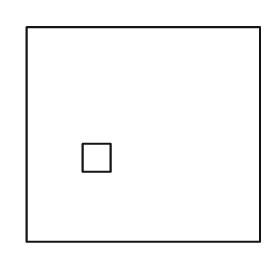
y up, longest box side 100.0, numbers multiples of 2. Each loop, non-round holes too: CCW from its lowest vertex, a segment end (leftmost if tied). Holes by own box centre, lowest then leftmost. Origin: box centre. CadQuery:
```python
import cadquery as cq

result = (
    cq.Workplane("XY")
    .moveTo(-50.0, -46.0)
    .lineTo(50.0, -46.0)
    .lineTo(50.0, 46.0)
    .lineTo(-50.0, 46.0)
    .close()
    .moveTo(-26.0, -16.0)
    .lineTo(-14.0, -16.0)
    .lineTo(-14.0, -4.0)
    .lineTo(-26.0, -4.0)
    .close()
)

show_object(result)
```